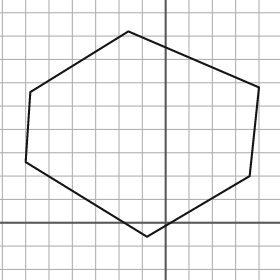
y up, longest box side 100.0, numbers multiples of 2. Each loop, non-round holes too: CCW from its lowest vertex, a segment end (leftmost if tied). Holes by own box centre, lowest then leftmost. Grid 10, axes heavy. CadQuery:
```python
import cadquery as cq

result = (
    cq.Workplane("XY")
    .moveTo(-8.0, -6.0)
    .lineTo(36.0, 20.0)
    .lineTo(40.0, 58.0)
    .lineTo(-16.0, 82.0)
    .lineTo(-58.0, 56.0)
    .lineTo(-60.0, 26.0)
    .close()
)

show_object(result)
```